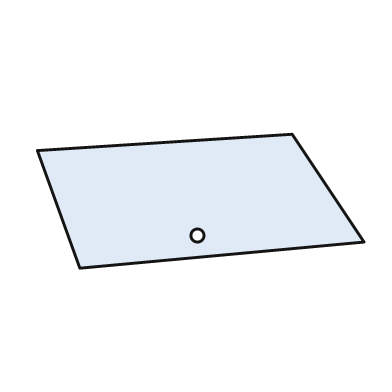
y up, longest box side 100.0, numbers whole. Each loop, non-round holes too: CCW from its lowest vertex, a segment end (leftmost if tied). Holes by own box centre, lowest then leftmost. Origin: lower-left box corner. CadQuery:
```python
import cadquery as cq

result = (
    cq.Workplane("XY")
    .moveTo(13.0, 0.0)
    .lineTo(100.0, 8.0)
    .lineTo(78.0, 41.0)
    .lineTo(0.0, 36.0)
    .close()
    .moveTo(49.0, 10.0)
    .circle(2.0)
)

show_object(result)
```